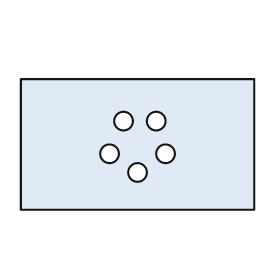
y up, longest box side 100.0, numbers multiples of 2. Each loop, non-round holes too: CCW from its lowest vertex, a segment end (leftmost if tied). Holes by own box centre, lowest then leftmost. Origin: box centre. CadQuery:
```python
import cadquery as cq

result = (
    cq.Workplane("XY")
    .moveTo(-50.0, -28.0)
    .lineTo(50.0, -28.0)
    .lineTo(50.0, 28.0)
    .lineTo(-50.0, 28.0)
    .close()
    .moveTo(0.0, -12.0)
    .circle(4.0)
    .moveTo(-12.0, -4.0)
    .circle(4.0)
    .moveTo(12.0, -4.0)
    .circle(4.0)
    .moveTo(-6.0, 10.0)
    .circle(4.0)
    .moveTo(8.0, 10.0)
    .circle(4.0)
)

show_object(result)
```